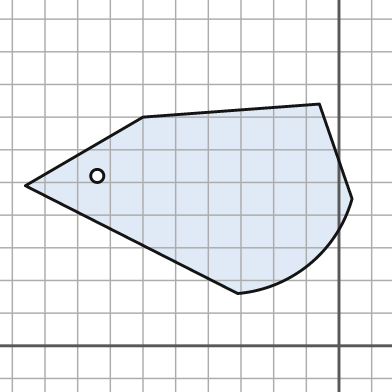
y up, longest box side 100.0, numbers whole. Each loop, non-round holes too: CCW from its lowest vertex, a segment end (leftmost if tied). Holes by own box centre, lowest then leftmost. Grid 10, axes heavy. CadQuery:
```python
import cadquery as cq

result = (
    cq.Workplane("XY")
    .moveTo(-31.0, 16.0)
    .threePointArc((-9.0, 25.0), (4.0, 45.0))
    .lineTo(-6.0, 74.0)
    .lineTo(-60.0, 70.0)
    .lineTo(-96.0, 49.0)
    .close()
    .moveTo(-74.0, 52.0)
    .circle(2.0)
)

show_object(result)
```